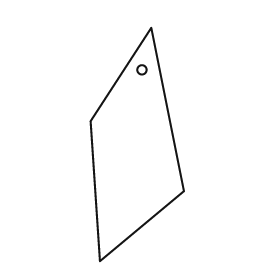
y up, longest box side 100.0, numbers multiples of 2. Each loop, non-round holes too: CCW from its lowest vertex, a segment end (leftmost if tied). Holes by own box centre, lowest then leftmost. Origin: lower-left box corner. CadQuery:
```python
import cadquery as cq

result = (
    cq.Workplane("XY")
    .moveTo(4.0, 0.0)
    .lineTo(40.0, 30.0)
    .lineTo(26.0, 100.0)
    .lineTo(0.0, 60.0)
    .close()
    .moveTo(22.0, 82.0)
    .circle(2.0)
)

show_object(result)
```